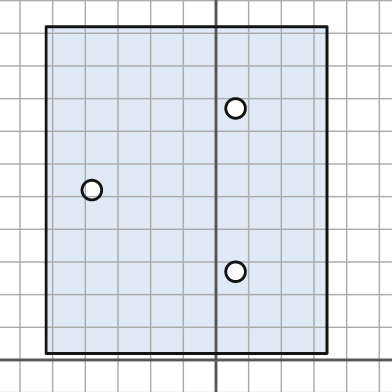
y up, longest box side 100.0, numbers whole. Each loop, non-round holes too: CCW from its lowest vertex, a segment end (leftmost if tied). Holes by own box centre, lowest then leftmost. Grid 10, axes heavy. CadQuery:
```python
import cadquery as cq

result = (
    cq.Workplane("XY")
    .moveTo(-52.0, 2.0)
    .lineTo(34.0, 2.0)
    .lineTo(34.0, 102.0)
    .lineTo(-52.0, 102.0)
    .close()
    .moveTo(6.0, 27.0)
    .circle(3.0)
    .moveTo(-38.0, 52.0)
    .circle(3.0)
    .moveTo(6.0, 77.0)
    .circle(3.0)
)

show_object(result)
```